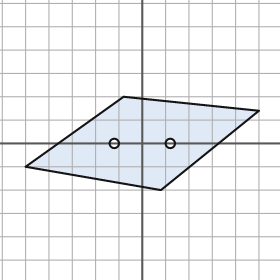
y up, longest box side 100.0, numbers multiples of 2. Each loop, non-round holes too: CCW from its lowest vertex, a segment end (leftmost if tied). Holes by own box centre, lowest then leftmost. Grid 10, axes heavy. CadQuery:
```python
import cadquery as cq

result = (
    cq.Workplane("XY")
    .moveTo(8.0, -20.0)
    .lineTo(50.0, 14.0)
    .lineTo(-8.0, 20.0)
    .lineTo(-50.0, -10.0)
    .close()
    .moveTo(-12.0, 0.0)
    .circle(2.0)
    .moveTo(12.0, 0.0)
    .circle(2.0)
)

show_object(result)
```